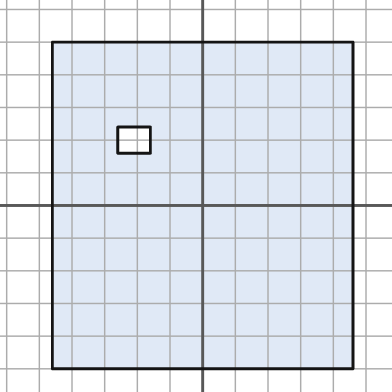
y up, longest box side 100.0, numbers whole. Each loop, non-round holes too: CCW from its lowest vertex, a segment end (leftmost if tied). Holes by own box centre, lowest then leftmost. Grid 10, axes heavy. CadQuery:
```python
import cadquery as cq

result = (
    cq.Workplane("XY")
    .moveTo(-46.0, -50.0)
    .lineTo(46.0, -50.0)
    .lineTo(46.0, 50.0)
    .lineTo(-46.0, 50.0)
    .close()
    .moveTo(-26.0, 16.0)
    .lineTo(-16.0, 16.0)
    .lineTo(-16.0, 24.0)
    .lineTo(-26.0, 24.0)
    .close()
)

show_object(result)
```